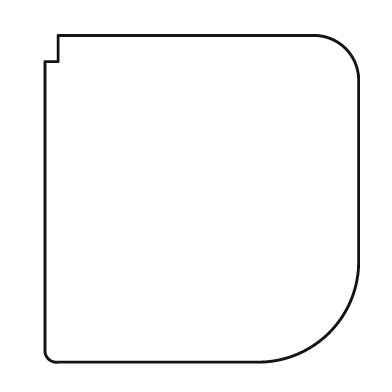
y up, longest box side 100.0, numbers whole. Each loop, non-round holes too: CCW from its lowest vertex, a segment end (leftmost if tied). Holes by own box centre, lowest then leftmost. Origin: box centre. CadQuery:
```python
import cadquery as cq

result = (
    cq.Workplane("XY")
    .moveTo(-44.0, -50.0)
    .lineTo(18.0, -50.0)
    .threePointArc((39.0, -41.0), (48.0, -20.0))
    .lineTo(48.0, 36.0)
    .threePointArc((44.0, 46.0), (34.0, 50.0))
    .lineTo(-44.0, 50.0)
    .lineTo(-44.0, 42.0)
    .lineTo(-48.0, 42.0)
    .lineTo(-48.0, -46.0)
    .threePointArc((-47.0, -49.0), (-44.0, -50.0))
    .close()
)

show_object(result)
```